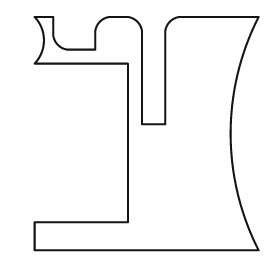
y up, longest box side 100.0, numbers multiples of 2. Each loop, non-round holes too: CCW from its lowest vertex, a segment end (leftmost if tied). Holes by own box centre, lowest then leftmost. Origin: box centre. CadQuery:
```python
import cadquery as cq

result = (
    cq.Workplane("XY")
    .moveTo(-48.0, -50.0)
    .lineTo(48.0, -50.0)
    .threePointArc((36.0, 0.0), (48.0, 50.0))
    .lineTo(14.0, 50.0)
    .threePointArc((10.0, 48.0), (8.0, 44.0))
    .lineTo(8.0, 4.0)
    .lineTo(-2.0, 4.0)
    .lineTo(-2.0, 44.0)
    .threePointArc((-4.0, 48.0), (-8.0, 50.0))
    .lineTo(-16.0, 50.0)
    .threePointArc((-20.0, 48.0), (-22.0, 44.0))
    .lineTo(-22.0, 36.0)
    .lineTo(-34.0, 36.0)
    .threePointArc((-38.0, 38.0), (-40.0, 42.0))
    .lineTo(-40.0, 50.0)
    .lineTo(-48.0, 50.0)
    .threePointArc((-44.0, 40.0), (-48.0, 30.0))
    .lineTo(-8.0, 30.0)
    .lineTo(-8.0, -38.0)
    .lineTo(-48.0, -38.0)
    .close()
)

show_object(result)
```